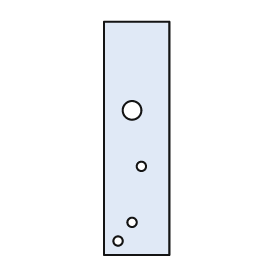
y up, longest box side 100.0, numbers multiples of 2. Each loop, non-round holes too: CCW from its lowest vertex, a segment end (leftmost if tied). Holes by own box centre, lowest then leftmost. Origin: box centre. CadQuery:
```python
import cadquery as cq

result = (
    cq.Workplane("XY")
    .moveTo(-14.0, -50.0)
    .lineTo(14.0, -50.0)
    .lineTo(14.0, 50.0)
    .lineTo(-14.0, 50.0)
    .close()
    .moveTo(-8.0, -44.0)
    .circle(2.0)
    .moveTo(-2.0, -36.0)
    .circle(2.0)
    .moveTo(2.0, -12.0)
    .circle(2.0)
    .moveTo(-2.0, 12.0)
    .circle(4.0)
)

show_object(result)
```